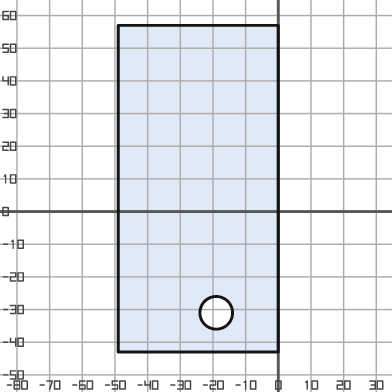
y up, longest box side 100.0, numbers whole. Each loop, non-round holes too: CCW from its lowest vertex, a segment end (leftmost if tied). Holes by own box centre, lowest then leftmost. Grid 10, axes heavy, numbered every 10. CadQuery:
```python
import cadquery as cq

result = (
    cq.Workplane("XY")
    .moveTo(-49.0, -43.0)
    .lineTo(0.0, -43.0)
    .lineTo(0.0, 57.0)
    .lineTo(-49.0, 57.0)
    .close()
    .moveTo(-19.0, -31.0)
    .circle(5.0)
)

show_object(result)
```